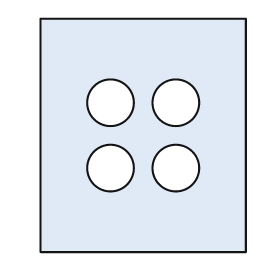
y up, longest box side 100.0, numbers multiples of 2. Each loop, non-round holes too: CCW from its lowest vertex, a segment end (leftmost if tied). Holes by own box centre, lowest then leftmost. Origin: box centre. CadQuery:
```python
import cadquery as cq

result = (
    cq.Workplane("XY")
    .moveTo(-44.0, -50.0)
    .lineTo(44.0, -50.0)
    .lineTo(44.0, 50.0)
    .lineTo(-44.0, 50.0)
    .close()
    .moveTo(-14.0, -14.0)
    .circle(10.0)
    .moveTo(14.0, -14.0)
    .circle(10.0)
    .moveTo(-14.0, 14.0)
    .circle(10.0)
    .moveTo(14.0, 14.0)
    .circle(10.0)
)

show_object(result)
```